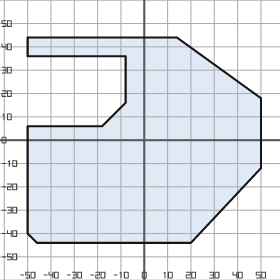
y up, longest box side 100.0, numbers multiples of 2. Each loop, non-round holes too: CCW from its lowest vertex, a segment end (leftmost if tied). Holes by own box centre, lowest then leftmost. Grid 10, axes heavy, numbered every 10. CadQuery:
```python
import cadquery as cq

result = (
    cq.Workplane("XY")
    .moveTo(-46.0, -44.0)
    .lineTo(20.0, -44.0)
    .lineTo(50.0, -12.0)
    .lineTo(50.0, 18.0)
    .lineTo(14.0, 44.0)
    .lineTo(-50.0, 44.0)
    .lineTo(-50.0, 36.0)
    .lineTo(-8.0, 36.0)
    .lineTo(-8.0, 16.0)
    .lineTo(-18.0, 6.0)
    .lineTo(-50.0, 6.0)
    .lineTo(-50.0, -40.0)
    .close()
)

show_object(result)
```